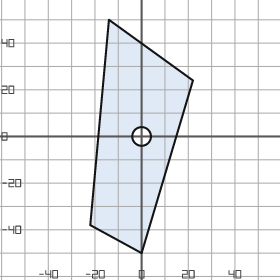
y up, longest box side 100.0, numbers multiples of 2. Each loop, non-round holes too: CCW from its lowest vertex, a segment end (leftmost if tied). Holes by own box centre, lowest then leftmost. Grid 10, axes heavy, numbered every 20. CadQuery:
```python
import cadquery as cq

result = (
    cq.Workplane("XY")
    .moveTo(0.0, -50.0)
    .lineTo(22.0, 24.0)
    .lineTo(-14.0, 50.0)
    .lineTo(-22.0, -38.0)
    .close()
    .moveTo(0.0, 0.0)
    .circle(4.0)
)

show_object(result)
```